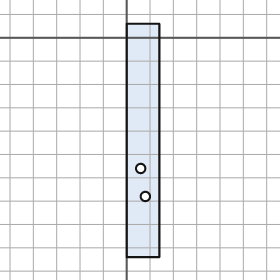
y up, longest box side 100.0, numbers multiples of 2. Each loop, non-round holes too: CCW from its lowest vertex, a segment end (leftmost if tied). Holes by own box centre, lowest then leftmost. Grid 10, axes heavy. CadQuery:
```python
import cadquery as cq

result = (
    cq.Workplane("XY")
    .moveTo(0.0, -94.0)
    .lineTo(14.0, -94.0)
    .lineTo(14.0, 6.0)
    .lineTo(0.0, 6.0)
    .close()
    .moveTo(8.0, -68.0)
    .circle(2.0)
    .moveTo(6.0, -56.0)
    .circle(2.0)
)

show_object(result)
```